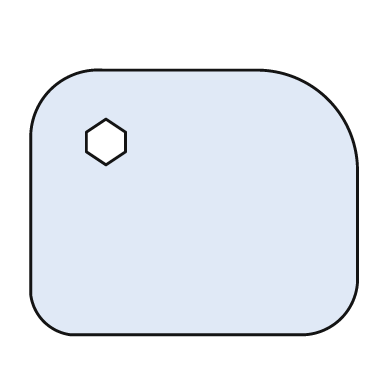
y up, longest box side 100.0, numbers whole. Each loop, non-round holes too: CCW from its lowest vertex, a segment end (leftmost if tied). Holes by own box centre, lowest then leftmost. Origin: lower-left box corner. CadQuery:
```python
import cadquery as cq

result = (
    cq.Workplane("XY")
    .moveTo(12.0, 0.0)
    .lineTo(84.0, 0.0)
    .threePointArc((95.0, 5.0), (100.0, 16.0))
    .lineTo(100.0, 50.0)
    .threePointArc((91.0, 72.0), (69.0, 81.0))
    .lineTo(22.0, 81.0)
    .threePointArc((6.0, 75.0), (0.0, 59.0))
    .lineTo(0.0, 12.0)
    .threePointArc((4.0, 4.0), (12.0, 0.0))
    .close()
    .moveTo(23.0, 52.0)
    .lineTo(29.0, 56.0)
    .lineTo(29.0, 62.0)
    .lineTo(23.0, 66.0)
    .lineTo(17.0, 62.0)
    .lineTo(17.0, 56.0)
    .close()
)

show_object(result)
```